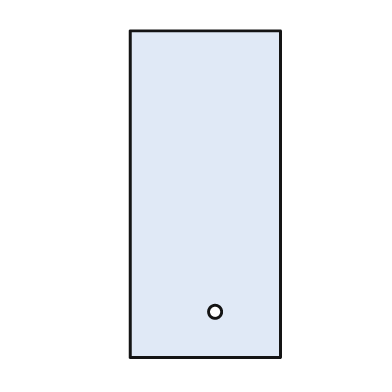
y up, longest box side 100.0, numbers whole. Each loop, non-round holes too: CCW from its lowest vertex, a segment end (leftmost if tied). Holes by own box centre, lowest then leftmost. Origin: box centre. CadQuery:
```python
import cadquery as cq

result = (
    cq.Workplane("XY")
    .moveTo(-23.0, -50.0)
    .lineTo(23.0, -50.0)
    .lineTo(23.0, 50.0)
    .lineTo(-23.0, 50.0)
    .close()
    .moveTo(3.0, -36.0)
    .circle(2.0)
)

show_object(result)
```